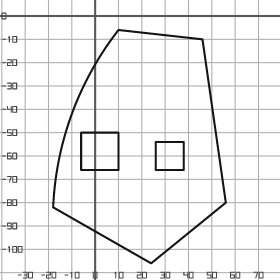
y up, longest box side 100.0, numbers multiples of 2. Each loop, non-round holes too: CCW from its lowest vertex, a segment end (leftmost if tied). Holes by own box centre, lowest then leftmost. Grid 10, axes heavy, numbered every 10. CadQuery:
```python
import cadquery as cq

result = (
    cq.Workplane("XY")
    .moveTo(24.0, -106.0)
    .lineTo(56.0, -80.0)
    .lineTo(46.0, -10.0)
    .lineTo(10.0, -6.0)
    .threePointArc((-10.0, -42.0), (-18.0, -82.0))
    .close()
    .moveTo(26.0, -66.0)
    .lineTo(38.0, -66.0)
    .lineTo(38.0, -54.0)
    .lineTo(26.0, -54.0)
    .close()
    .moveTo(-6.0, -66.0)
    .lineTo(10.0, -66.0)
    .lineTo(10.0, -50.0)
    .lineTo(-6.0, -50.0)
    .close()
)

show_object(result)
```